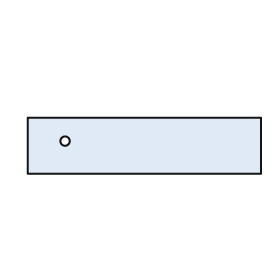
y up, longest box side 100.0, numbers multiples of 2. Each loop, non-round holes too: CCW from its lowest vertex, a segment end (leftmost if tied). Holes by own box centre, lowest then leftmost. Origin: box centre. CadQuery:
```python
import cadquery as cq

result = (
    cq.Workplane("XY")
    .moveTo(-50.0, -12.0)
    .lineTo(50.0, -12.0)
    .lineTo(50.0, 12.0)
    .lineTo(-50.0, 12.0)
    .close()
    .moveTo(-34.0, 2.0)
    .circle(2.0)
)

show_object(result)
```